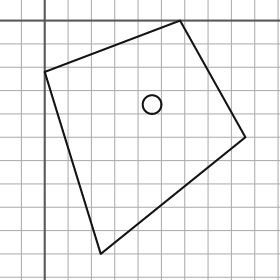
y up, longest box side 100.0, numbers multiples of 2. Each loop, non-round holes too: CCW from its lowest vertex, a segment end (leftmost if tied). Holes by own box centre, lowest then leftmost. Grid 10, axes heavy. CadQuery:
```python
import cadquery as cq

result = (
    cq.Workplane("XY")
    .moveTo(24.0, -100.0)
    .lineTo(86.0, -50.0)
    .lineTo(58.0, 0.0)
    .lineTo(0.0, -22.0)
    .close()
    .moveTo(46.0, -36.0)
    .circle(4.0)
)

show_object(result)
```